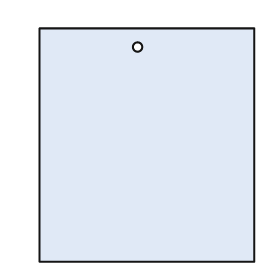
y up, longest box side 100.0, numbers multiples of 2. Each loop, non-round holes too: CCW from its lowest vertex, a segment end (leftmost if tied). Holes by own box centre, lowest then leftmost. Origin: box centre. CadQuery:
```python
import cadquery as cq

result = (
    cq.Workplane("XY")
    .moveTo(-46.0, -50.0)
    .lineTo(46.0, -50.0)
    .lineTo(46.0, 50.0)
    .lineTo(-46.0, 50.0)
    .close()
    .moveTo(-4.0, 42.0)
    .circle(2.0)
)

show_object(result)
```